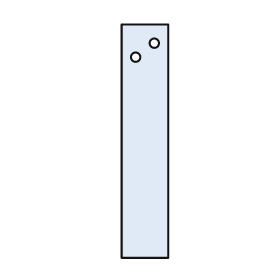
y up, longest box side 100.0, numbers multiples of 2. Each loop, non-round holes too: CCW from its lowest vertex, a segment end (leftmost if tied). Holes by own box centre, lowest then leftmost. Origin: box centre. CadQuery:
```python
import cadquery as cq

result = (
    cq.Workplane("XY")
    .moveTo(-10.0, -50.0)
    .lineTo(10.0, -50.0)
    .lineTo(10.0, 50.0)
    .lineTo(-10.0, 50.0)
    .close()
    .moveTo(-4.0, 36.0)
    .circle(2.0)
    .moveTo(4.0, 42.0)
    .circle(2.0)
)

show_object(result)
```